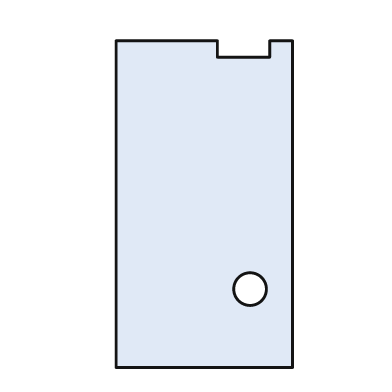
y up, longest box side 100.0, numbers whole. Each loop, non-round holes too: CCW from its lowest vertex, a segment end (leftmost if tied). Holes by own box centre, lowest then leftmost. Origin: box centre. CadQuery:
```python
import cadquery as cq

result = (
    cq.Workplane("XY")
    .moveTo(-27.0, -50.0)
    .lineTo(27.0, -50.0)
    .lineTo(27.0, 50.0)
    .lineTo(20.0, 50.0)
    .lineTo(20.0, 45.0)
    .lineTo(4.0, 45.0)
    .lineTo(4.0, 50.0)
    .lineTo(-27.0, 50.0)
    .close()
    .moveTo(14.0, -26.0)
    .circle(5.0)
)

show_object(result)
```